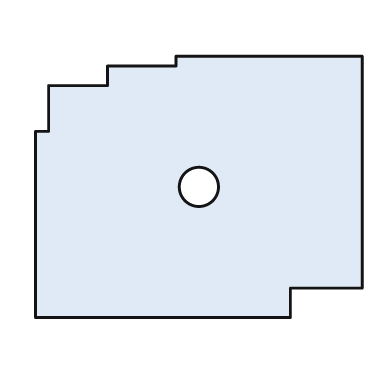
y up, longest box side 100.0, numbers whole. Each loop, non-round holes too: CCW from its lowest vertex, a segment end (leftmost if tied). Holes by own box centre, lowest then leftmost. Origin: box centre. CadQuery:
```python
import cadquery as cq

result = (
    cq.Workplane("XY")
    .moveTo(-50.0, -40.0)
    .lineTo(28.0, -40.0)
    .lineTo(28.0, -31.0)
    .lineTo(50.0, -31.0)
    .lineTo(50.0, 40.0)
    .lineTo(-7.0, 40.0)
    .lineTo(-7.0, 37.0)
    .lineTo(-28.0, 37.0)
    .lineTo(-28.0, 31.0)
    .lineTo(-46.0, 31.0)
    .lineTo(-46.0, 17.0)
    .lineTo(-50.0, 17.0)
    .close()
    .moveTo(0.0, 0.0)
    .circle(6.0)
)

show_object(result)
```